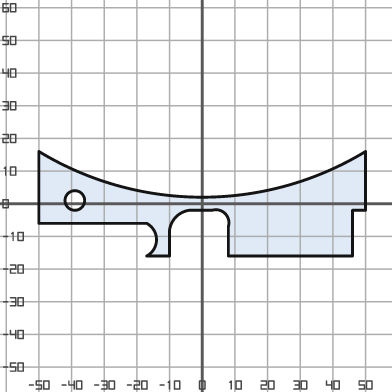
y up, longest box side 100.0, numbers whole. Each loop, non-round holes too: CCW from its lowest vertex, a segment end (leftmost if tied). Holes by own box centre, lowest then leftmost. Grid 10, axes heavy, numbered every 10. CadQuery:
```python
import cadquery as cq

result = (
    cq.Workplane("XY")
    .moveTo(-17.0, -16.0)
    .lineTo(-10.0, -16.0)
    .lineTo(-10.0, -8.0)
    .threePointArc((-8.0, -4.0), (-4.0, -2.0))
    .lineTo(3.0, -2.0)
    .threePointArc((7.0, -3.0), (8.0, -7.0))
    .lineTo(8.0, -16.0)
    .lineTo(46.0, -16.0)
    .lineTo(46.0, -2.0)
    .lineTo(50.0, -2.0)
    .lineTo(50.0, 16.0)
    .threePointArc((0.0, 2.0), (-50.0, 16.0))
    .lineTo(-50.0, -6.0)
    .lineTo(-17.0, -6.0)
    .threePointArc((-14.0, -11.0), (-17.0, -16.0))
    .close()
    .moveTo(-39.0, 1.0)
    .circle(3.0)
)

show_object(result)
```